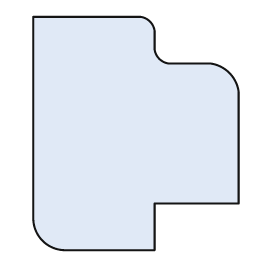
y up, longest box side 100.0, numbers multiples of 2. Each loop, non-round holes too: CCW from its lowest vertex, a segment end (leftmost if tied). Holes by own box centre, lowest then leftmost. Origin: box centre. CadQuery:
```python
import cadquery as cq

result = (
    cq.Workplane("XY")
    .moveTo(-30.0, -50.0)
    .lineTo(8.0, -50.0)
    .lineTo(8.0, -30.0)
    .lineTo(44.0, -30.0)
    .lineTo(44.0, 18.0)
    .threePointArc((40.0, 26.0), (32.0, 30.0))
    .lineTo(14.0, 30.0)
    .threePointArc((10.0, 32.0), (8.0, 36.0))
    .lineTo(8.0, 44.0)
    .threePointArc((6.0, 48.0), (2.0, 50.0))
    .lineTo(-44.0, 50.0)
    .lineTo(-44.0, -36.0)
    .threePointArc((-40.0, -46.0), (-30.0, -50.0))
    .close()
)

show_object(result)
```